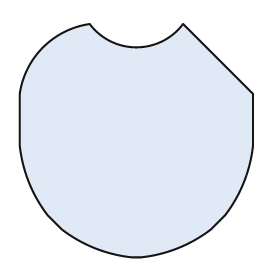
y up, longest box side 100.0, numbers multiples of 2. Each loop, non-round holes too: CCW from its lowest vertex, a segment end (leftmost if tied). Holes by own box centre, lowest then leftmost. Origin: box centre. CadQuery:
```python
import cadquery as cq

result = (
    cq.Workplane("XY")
    .moveTo(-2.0, -50.0)
    .lineTo(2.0, -50.0)
    .threePointArc((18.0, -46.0), (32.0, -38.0))
    .lineTo(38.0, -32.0)
    .threePointArc((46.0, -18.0), (50.0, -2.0))
    .lineTo(50.0, 20.0)
    .lineTo(20.0, 50.0)
    .threePointArc((0.0, 40.0), (-20.0, 50.0))
    .threePointArc((-40.0, 40.0), (-50.0, 20.0))
    .lineTo(-50.0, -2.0)
    .threePointArc((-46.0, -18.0), (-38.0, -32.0))
    .lineTo(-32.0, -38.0)
    .threePointArc((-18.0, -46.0), (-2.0, -50.0))
    .close()
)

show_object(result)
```